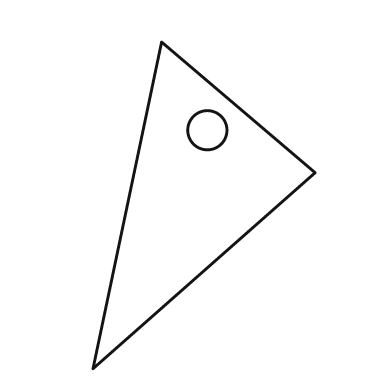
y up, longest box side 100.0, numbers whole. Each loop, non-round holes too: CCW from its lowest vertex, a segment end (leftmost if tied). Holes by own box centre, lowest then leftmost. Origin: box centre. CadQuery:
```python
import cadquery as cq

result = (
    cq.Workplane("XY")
    .moveTo(-34.0, -50.0)
    .lineTo(34.0, 10.0)
    .lineTo(-13.0, 50.0)
    .close()
    .moveTo(1.0, 23.0)
    .circle(6.0)
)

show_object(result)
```